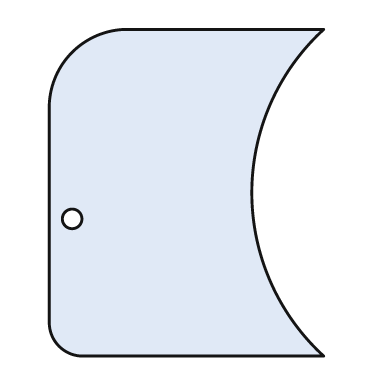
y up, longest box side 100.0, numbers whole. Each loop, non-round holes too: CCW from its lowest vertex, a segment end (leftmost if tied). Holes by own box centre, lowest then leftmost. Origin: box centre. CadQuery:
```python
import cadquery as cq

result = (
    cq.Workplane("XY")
    .moveTo(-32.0, -50.0)
    .lineTo(42.0, -50.0)
    .threePointArc((20.0, 0.0), (42.0, 50.0))
    .lineTo(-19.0, 50.0)
    .threePointArc((-35.0, 43.0), (-42.0, 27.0))
    .lineTo(-42.0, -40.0)
    .threePointArc((-39.0, -47.0), (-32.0, -50.0))
    .close()
    .moveTo(-35.0, -8.0)
    .circle(3.0)
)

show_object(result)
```